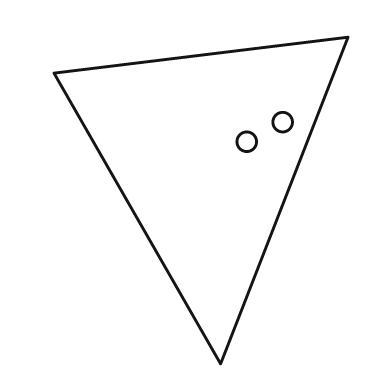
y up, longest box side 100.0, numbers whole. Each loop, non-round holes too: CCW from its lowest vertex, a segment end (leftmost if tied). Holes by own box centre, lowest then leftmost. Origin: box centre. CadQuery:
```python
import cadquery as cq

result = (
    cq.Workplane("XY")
    .moveTo(6.0, -50.0)
    .lineTo(45.0, 50.0)
    .lineTo(-45.0, 39.0)
    .close()
    .moveTo(14.0, 18.0)
    .circle(3.0)
    .moveTo(25.0, 24.0)
    .circle(3.0)
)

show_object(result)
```